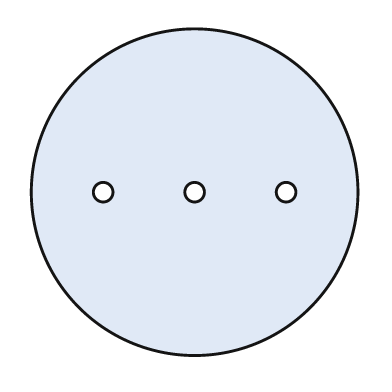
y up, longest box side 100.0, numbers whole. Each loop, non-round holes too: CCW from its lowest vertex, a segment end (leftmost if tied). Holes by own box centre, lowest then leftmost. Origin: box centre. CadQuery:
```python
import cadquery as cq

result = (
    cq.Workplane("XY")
    .moveTo(0.0, 0.0)
    .circle(50.0)
    .moveTo(-28.0, 0.0)
    .circle(3.0)
    .moveTo(0.0, 0.0)
    .circle(3.0)
    .moveTo(28.0, 0.0)
    .circle(3.0)
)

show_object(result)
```